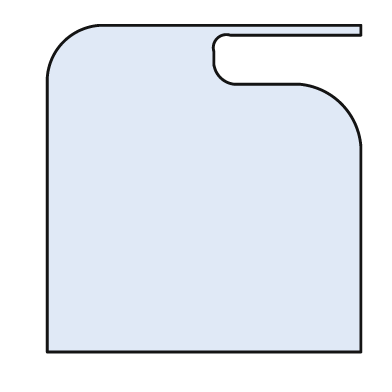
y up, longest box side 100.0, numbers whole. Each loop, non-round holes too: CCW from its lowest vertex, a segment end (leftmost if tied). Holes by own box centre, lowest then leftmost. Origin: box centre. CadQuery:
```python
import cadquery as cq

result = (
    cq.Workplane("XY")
    .moveTo(-48.0, -50.0)
    .lineTo(48.0, -50.0)
    .lineTo(48.0, 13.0)
    .threePointArc((42.0, 26.0), (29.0, 32.0))
    .lineTo(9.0, 32.0)
    .threePointArc((5.0, 34.0), (3.0, 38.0))
    .lineTo(3.0, 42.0)
    .threePointArc((4.0, 46.0), (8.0, 47.0))
    .lineTo(48.0, 47.0)
    .lineTo(48.0, 50.0)
    .lineTo(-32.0, 50.0)
    .threePointArc((-43.0, 45.0), (-48.0, 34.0))
    .close()
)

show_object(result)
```